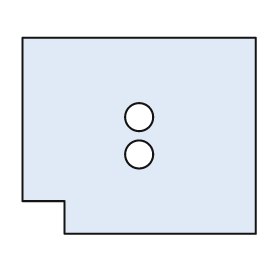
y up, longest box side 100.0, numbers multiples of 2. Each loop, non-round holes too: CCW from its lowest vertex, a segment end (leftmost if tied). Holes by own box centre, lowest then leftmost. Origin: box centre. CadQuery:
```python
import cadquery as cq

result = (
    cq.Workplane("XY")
    .moveTo(-32.0, -42.0)
    .lineTo(50.0, -42.0)
    .lineTo(50.0, 42.0)
    .lineTo(-50.0, 42.0)
    .lineTo(-50.0, -28.0)
    .lineTo(-32.0, -28.0)
    .close()
    .moveTo(0.0, -8.0)
    .circle(6.0)
    .moveTo(0.0, 8.0)
    .circle(6.0)
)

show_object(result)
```